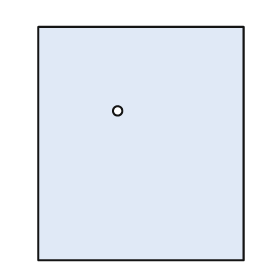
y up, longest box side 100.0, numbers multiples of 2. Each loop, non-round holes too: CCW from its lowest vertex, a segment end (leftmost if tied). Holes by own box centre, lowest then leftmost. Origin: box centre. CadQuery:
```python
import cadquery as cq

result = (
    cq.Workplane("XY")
    .moveTo(-44.0, -50.0)
    .lineTo(44.0, -50.0)
    .lineTo(44.0, 50.0)
    .lineTo(-44.0, 50.0)
    .close()
    .moveTo(-10.0, 14.0)
    .circle(2.0)
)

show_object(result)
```